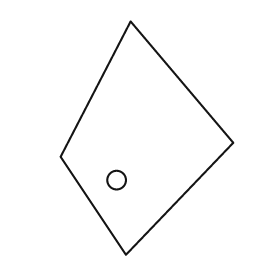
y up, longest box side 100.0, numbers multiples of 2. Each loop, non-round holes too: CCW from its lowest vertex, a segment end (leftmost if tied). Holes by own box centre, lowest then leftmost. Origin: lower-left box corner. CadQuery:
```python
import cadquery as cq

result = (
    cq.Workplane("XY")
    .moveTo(28.0, 0.0)
    .lineTo(74.0, 48.0)
    .lineTo(30.0, 100.0)
    .lineTo(0.0, 42.0)
    .close()
    .moveTo(24.0, 32.0)
    .circle(4.0)
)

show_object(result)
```